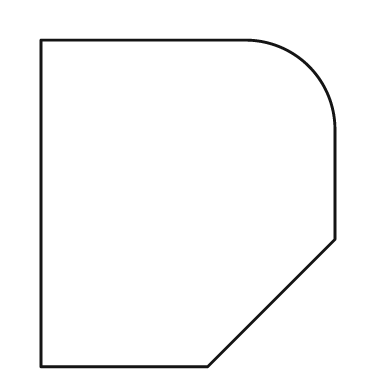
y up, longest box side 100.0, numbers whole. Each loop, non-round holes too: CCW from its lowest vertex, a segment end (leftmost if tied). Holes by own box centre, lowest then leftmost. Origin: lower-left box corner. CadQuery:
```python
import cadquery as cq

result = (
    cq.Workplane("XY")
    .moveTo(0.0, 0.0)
    .lineTo(51.0, 0.0)
    .lineTo(90.0, 39.0)
    .lineTo(90.0, 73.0)
    .threePointArc((82.0, 92.0), (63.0, 100.0))
    .lineTo(0.0, 100.0)
    .close()
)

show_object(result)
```